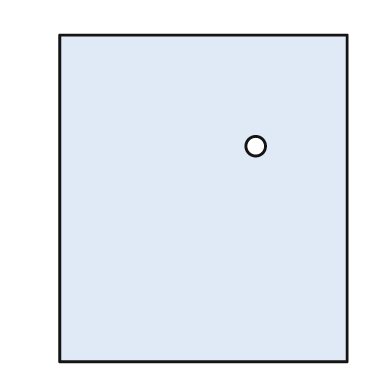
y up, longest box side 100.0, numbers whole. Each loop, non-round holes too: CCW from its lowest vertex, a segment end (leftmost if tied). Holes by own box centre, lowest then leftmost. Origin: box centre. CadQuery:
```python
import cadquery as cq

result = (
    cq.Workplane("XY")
    .moveTo(-44.0, -50.0)
    .lineTo(44.0, -50.0)
    .lineTo(44.0, 50.0)
    .lineTo(-44.0, 50.0)
    .close()
    .moveTo(16.0, 16.0)
    .circle(3.0)
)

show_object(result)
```